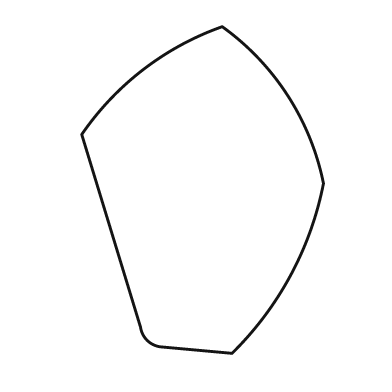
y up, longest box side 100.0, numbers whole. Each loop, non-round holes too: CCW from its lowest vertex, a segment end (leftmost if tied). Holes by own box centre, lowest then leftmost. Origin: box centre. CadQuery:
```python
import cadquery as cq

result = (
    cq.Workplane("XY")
    .moveTo(9.0, -50.0)
    .threePointArc((27.0, -26.0), (37.0, 2.0))
    .threePointArc((26.0, 29.0), (6.0, 50.0))
    .threePointArc((-18.0, 37.0), (-37.0, 17.0))
    .lineTo(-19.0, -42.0)
    .threePointArc((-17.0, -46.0), (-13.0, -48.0))
    .close()
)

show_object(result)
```